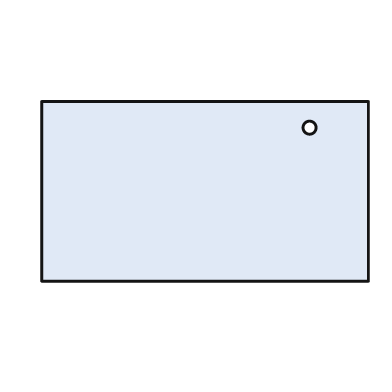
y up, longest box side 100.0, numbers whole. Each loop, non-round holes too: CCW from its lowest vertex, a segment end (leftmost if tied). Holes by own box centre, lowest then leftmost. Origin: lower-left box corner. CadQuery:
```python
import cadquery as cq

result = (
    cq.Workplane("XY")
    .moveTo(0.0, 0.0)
    .lineTo(100.0, 0.0)
    .lineTo(100.0, 55.0)
    .lineTo(0.0, 55.0)
    .close()
    .moveTo(82.0, 47.0)
    .circle(2.0)
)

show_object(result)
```